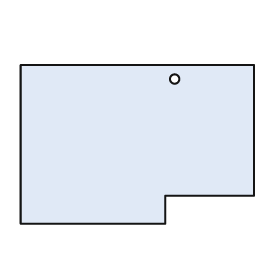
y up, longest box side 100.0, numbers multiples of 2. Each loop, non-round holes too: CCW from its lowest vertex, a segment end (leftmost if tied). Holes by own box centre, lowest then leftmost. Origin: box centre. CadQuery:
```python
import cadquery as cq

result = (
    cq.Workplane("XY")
    .moveTo(-50.0, -34.0)
    .lineTo(12.0, -34.0)
    .lineTo(12.0, -22.0)
    .lineTo(50.0, -22.0)
    .lineTo(50.0, 34.0)
    .lineTo(-50.0, 34.0)
    .close()
    .moveTo(16.0, 28.0)
    .circle(2.0)
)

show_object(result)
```